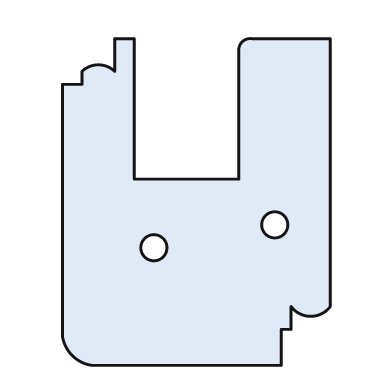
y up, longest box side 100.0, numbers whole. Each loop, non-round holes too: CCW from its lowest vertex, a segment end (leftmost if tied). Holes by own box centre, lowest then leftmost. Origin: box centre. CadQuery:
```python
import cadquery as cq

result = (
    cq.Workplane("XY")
    .moveTo(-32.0, -50.0)
    .lineTo(26.0, -50.0)
    .lineTo(26.0, -39.0)
    .lineTo(29.0, -39.0)
    .lineTo(29.0, -32.0)
    .threePointArc((35.0, -35.0), (41.0, -32.0))
    .lineTo(41.0, 50.0)
    .lineTo(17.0, 50.0)
    .threePointArc((14.0, 49.0), (13.0, 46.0))
    .lineTo(13.0, 7.0)
    .lineTo(-19.0, 7.0)
    .lineTo(-19.0, 50.0)
    .lineTo(-25.0, 50.0)
    .lineTo(-25.0, 40.0)
    .threePointArc((-30.0, 42.0), (-35.0, 40.0))
    .lineTo(-35.0, 36.0)
    .lineTo(-41.0, 36.0)
    .lineTo(-41.0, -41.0)
    .threePointArc((-38.0, -47.0), (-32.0, -50.0))
    .close()
    .moveTo(-13.0, -14.0)
    .circle(4.0)
    .moveTo(24.0, -7.0)
    .circle(4.0)
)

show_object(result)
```